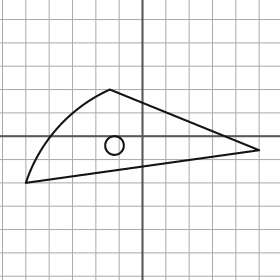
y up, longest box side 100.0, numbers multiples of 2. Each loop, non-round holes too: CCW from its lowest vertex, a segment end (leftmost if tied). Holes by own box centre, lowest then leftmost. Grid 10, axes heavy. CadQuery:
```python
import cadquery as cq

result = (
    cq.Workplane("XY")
    .moveTo(-50.0, -20.0)
    .lineTo(50.0, -6.0)
    .lineTo(-14.0, 20.0)
    .threePointArc((-36.0, 4.0), (-50.0, -20.0))
    .close()
    .moveTo(-12.0, -4.0)
    .circle(4.0)
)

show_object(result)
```